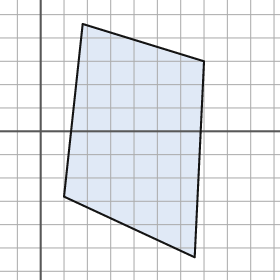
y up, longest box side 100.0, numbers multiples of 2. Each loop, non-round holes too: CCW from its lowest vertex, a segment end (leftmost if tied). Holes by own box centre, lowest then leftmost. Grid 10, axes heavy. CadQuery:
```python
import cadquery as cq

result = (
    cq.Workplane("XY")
    .moveTo(66.0, -54.0)
    .lineTo(70.0, 30.0)
    .lineTo(18.0, 46.0)
    .lineTo(10.0, -28.0)
    .close()
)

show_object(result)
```